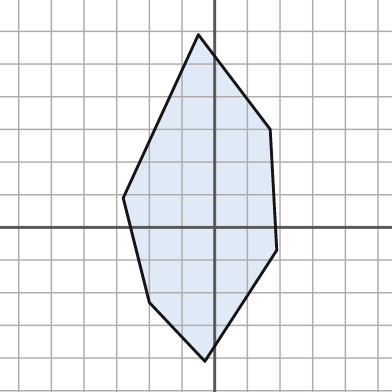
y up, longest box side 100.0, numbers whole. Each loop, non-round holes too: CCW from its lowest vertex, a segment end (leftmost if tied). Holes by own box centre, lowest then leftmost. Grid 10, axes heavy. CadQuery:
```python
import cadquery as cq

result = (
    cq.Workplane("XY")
    .moveTo(-3.0, -41.0)
    .lineTo(19.0, -7.0)
    .lineTo(17.0, 30.0)
    .lineTo(-5.0, 59.0)
    .lineTo(-28.0, 9.0)
    .lineTo(-20.0, -23.0)
    .close()
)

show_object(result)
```